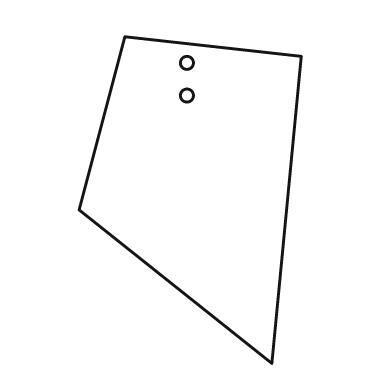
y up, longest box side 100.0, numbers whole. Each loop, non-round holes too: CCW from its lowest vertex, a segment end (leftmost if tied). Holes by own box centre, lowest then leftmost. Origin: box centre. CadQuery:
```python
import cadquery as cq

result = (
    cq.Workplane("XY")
    .moveTo(25.0, -50.0)
    .lineTo(34.0, 44.0)
    .lineTo(-20.0, 50.0)
    .lineTo(-34.0, -3.0)
    .close()
    .moveTo(-1.0, 32.0)
    .circle(2.0)
    .moveTo(-1.0, 42.0)
    .circle(2.0)
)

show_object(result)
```